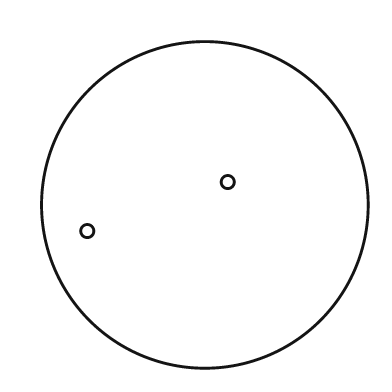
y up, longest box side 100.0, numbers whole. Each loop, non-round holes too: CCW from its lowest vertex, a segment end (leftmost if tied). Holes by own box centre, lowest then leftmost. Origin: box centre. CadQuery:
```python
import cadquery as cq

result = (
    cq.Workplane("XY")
    .moveTo(0.0, 0.0)
    .circle(50.0)
    .moveTo(-36.0, -8.0)
    .circle(2.0)
    .moveTo(7.0, 7.0)
    .circle(2.0)
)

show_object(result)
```